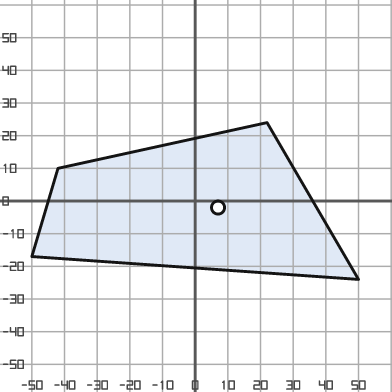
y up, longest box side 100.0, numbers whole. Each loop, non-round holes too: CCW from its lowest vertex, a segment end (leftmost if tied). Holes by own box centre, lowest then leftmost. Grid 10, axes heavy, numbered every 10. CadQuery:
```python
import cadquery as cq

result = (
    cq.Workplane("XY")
    .moveTo(50.0, -24.0)
    .lineTo(22.0, 24.0)
    .lineTo(-42.0, 10.0)
    .lineTo(-50.0, -17.0)
    .close()
    .moveTo(7.0, -2.0)
    .circle(2.0)
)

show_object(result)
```